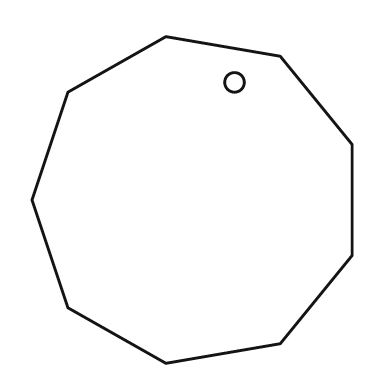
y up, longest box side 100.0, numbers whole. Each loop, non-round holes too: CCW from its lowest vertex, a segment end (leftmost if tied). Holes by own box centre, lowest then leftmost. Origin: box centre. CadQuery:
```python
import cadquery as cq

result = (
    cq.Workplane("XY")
    .moveTo(-8.0, -50.0)
    .lineTo(27.0, -44.0)
    .lineTo(49.0, -17.0)
    .lineTo(49.0, 17.0)
    .lineTo(27.0, 44.0)
    .lineTo(-8.0, 50.0)
    .lineTo(-38.0, 33.0)
    .lineTo(-49.0, 0.0)
    .lineTo(-38.0, -33.0)
    .close()
    .moveTo(13.0, 36.0)
    .circle(3.0)
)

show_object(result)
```